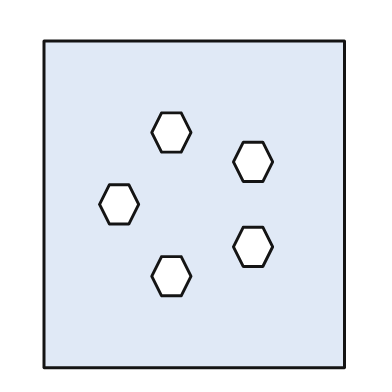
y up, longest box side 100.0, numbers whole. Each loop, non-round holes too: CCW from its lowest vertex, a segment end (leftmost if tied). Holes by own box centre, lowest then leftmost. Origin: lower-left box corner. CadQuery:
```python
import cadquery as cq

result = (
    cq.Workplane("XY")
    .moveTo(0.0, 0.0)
    .lineTo(92.0, 0.0)
    .lineTo(92.0, 100.0)
    .lineTo(0.0, 100.0)
    .close()
    .moveTo(36.0, 22.0)
    .lineTo(42.0, 22.0)
    .lineTo(45.0, 28.0)
    .lineTo(42.0, 34.0)
    .lineTo(36.0, 34.0)
    .lineTo(33.0, 28.0)
    .close()
    .moveTo(61.0, 31.0)
    .lineTo(67.0, 31.0)
    .lineTo(70.0, 37.0)
    .lineTo(67.0, 43.0)
    .lineTo(61.0, 43.0)
    .lineTo(58.0, 37.0)
    .close()
    .moveTo(20.0, 44.0)
    .lineTo(26.0, 44.0)
    .lineTo(29.0, 50.0)
    .lineTo(26.0, 56.0)
    .lineTo(20.0, 56.0)
    .lineTo(17.0, 50.0)
    .close()
    .moveTo(61.0, 57.0)
    .lineTo(67.0, 57.0)
    .lineTo(70.0, 63.0)
    .lineTo(67.0, 69.0)
    .lineTo(61.0, 69.0)
    .lineTo(58.0, 63.0)
    .close()
    .moveTo(36.0, 66.0)
    .lineTo(42.0, 66.0)
    .lineTo(45.0, 72.0)
    .lineTo(42.0, 78.0)
    .lineTo(36.0, 78.0)
    .lineTo(33.0, 72.0)
    .close()
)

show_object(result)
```